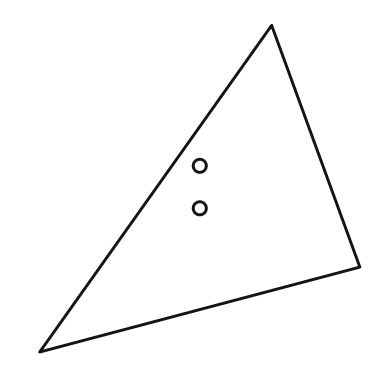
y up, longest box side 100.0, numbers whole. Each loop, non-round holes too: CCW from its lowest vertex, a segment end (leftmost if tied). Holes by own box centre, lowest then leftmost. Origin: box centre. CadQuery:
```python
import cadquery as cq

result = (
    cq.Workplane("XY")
    .moveTo(-49.0, -50.0)
    .lineTo(49.0, -24.0)
    .lineTo(22.0, 50.0)
    .close()
    .moveTo(0.0, -6.0)
    .circle(2.0)
    .moveTo(0.0, 7.0)
    .circle(2.0)
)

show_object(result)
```